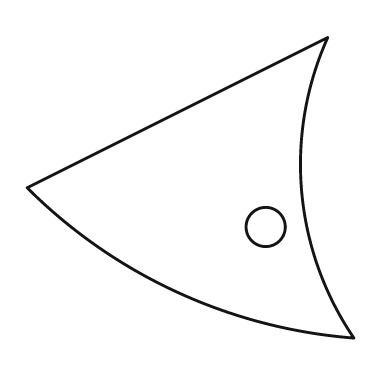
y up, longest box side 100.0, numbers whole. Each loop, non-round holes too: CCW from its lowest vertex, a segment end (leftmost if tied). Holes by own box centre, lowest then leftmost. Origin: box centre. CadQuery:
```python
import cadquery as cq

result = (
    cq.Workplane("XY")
    .moveTo(50.0, -46.0)
    .threePointArc((34.0, -1.0), (42.0, 46.0))
    .lineTo(-50.0, 0.0)
    .threePointArc((-4.0, -32.0), (50.0, -46.0))
    .close()
    .moveTo(23.0, -12.0)
    .circle(6.0)
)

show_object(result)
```